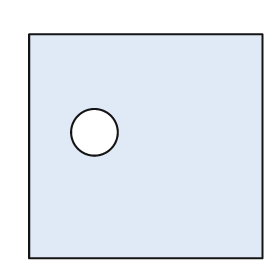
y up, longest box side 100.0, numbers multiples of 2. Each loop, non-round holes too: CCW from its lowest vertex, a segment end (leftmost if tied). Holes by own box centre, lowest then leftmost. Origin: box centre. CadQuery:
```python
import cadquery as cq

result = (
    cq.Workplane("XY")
    .moveTo(-50.0, -48.0)
    .lineTo(50.0, -48.0)
    .lineTo(50.0, 48.0)
    .lineTo(-50.0, 48.0)
    .close()
    .moveTo(-22.0, 6.0)
    .circle(10.0)
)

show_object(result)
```